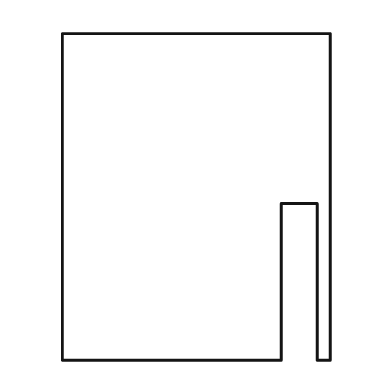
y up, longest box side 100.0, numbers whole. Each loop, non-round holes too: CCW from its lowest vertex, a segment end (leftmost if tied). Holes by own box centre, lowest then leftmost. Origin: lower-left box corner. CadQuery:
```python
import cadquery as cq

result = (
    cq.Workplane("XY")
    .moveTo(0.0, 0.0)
    .lineTo(67.0, 0.0)
    .lineTo(67.0, 48.0)
    .lineTo(78.0, 48.0)
    .lineTo(78.0, 0.0)
    .lineTo(82.0, 0.0)
    .lineTo(82.0, 100.0)
    .lineTo(0.0, 100.0)
    .close()
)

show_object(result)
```